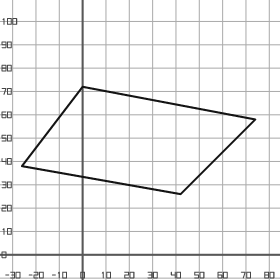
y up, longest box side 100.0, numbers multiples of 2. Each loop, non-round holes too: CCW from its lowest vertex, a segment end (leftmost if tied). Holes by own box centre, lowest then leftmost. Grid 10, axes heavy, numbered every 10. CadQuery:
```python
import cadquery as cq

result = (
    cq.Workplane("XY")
    .moveTo(42.0, 26.0)
    .lineTo(74.0, 58.0)
    .lineTo(0.0, 72.0)
    .lineTo(-26.0, 38.0)
    .close()
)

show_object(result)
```